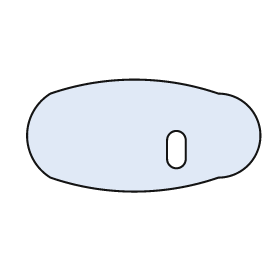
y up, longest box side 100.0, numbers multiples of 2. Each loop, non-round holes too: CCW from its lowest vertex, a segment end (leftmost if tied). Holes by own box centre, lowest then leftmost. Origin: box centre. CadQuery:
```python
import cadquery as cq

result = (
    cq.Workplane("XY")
    .moveTo(-40.0, -18.0)
    .threePointArc((-4.0, -24.0), (32.0, -18.0))
    .threePointArc((50.0, 0.0), (32.0, 18.0))
    .threePointArc((-4.0, 24.0), (-40.0, 18.0))
    .threePointArc((-50.0, 0.0), (-40.0, -18.0))
    .close()
    .moveTo(10.0, -10.0)
    .threePointArc((14.0, -14.0), (18.0, -10.0))
    .lineTo(18.0, -2.0)
    .threePointArc((14.0, 2.0), (10.0, -2.0))
    .close()
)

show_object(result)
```